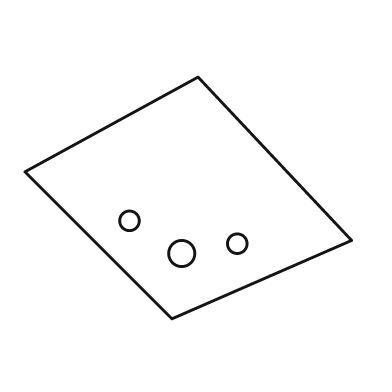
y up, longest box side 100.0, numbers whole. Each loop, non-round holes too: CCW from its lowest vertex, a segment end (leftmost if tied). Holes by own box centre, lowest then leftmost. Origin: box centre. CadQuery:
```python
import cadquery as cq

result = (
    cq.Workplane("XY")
    .moveTo(-5.0, -37.0)
    .lineTo(50.0, -13.0)
    .lineTo(3.0, 37.0)
    .lineTo(-50.0, 8.0)
    .close()
    .moveTo(-2.0, -17.0)
    .circle(4.0)
    .moveTo(15.0, -14.0)
    .circle(3.0)
    .moveTo(-18.0, -7.0)
    .circle(3.0)
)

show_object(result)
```